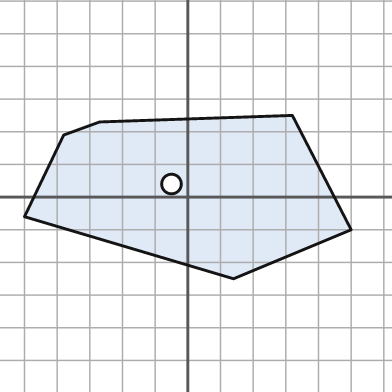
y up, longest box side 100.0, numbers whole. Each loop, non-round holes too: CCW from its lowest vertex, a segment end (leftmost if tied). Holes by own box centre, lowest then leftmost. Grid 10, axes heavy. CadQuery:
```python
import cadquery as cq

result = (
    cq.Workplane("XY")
    .moveTo(14.0, -25.0)
    .lineTo(50.0, -10.0)
    .lineTo(32.0, 25.0)
    .lineTo(-27.0, 23.0)
    .lineTo(-38.0, 19.0)
    .lineTo(-50.0, -6.0)
    .close()
    .moveTo(-5.0, 4.0)
    .circle(3.0)
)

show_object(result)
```